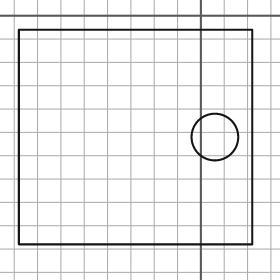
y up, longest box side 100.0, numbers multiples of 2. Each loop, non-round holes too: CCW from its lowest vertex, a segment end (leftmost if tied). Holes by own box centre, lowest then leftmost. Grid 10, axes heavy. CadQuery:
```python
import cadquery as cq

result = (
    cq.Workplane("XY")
    .moveTo(-78.0, -98.0)
    .lineTo(22.0, -98.0)
    .lineTo(22.0, -6.0)
    .lineTo(-78.0, -6.0)
    .close()
    .moveTo(6.0, -52.0)
    .circle(10.0)
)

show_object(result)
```